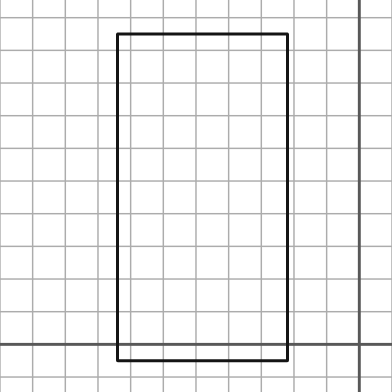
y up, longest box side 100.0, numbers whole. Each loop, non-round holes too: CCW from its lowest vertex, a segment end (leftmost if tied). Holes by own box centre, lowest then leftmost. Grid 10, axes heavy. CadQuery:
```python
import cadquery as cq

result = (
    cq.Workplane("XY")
    .moveTo(-74.0, -5.0)
    .lineTo(-22.0, -5.0)
    .lineTo(-22.0, 95.0)
    .lineTo(-74.0, 95.0)
    .close()
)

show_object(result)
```